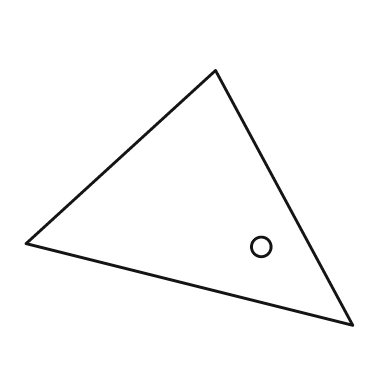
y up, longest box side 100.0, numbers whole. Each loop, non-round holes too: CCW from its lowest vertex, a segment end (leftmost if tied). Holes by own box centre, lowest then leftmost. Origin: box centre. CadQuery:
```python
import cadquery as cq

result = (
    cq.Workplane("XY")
    .moveTo(50.0, -39.0)
    .lineTo(8.0, 39.0)
    .lineTo(-50.0, -14.0)
    .close()
    .moveTo(22.0, -15.0)
    .circle(3.0)
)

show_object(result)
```